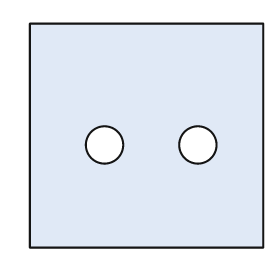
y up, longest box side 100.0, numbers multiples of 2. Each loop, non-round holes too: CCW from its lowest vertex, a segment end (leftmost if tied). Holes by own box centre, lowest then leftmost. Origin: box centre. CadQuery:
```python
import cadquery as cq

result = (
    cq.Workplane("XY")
    .moveTo(-50.0, -48.0)
    .lineTo(50.0, -48.0)
    .lineTo(50.0, 48.0)
    .lineTo(-50.0, 48.0)
    .close()
    .moveTo(-18.0, -4.0)
    .circle(8.0)
    .moveTo(22.0, -4.0)
    .circle(8.0)
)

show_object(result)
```